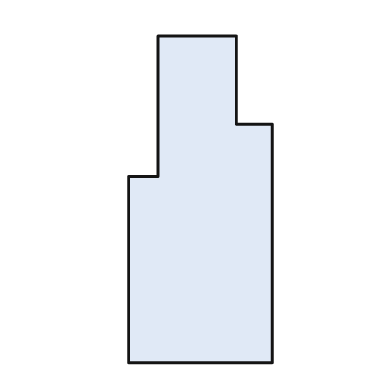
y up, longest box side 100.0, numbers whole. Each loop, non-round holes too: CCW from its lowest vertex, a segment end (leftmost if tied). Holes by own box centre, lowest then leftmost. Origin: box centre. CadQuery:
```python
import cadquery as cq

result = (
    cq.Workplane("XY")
    .moveTo(-22.0, -50.0)
    .lineTo(22.0, -50.0)
    .lineTo(22.0, 23.0)
    .lineTo(11.0, 23.0)
    .lineTo(11.0, 50.0)
    .lineTo(-13.0, 50.0)
    .lineTo(-13.0, 7.0)
    .lineTo(-22.0, 7.0)
    .close()
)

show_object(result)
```